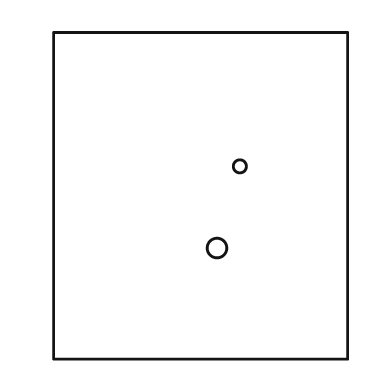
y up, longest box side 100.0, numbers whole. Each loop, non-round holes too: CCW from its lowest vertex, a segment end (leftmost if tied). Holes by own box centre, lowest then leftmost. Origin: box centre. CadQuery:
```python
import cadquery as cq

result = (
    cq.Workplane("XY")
    .moveTo(-45.0, -50.0)
    .lineTo(45.0, -50.0)
    .lineTo(45.0, 50.0)
    .lineTo(-45.0, 50.0)
    .close()
    .moveTo(5.0, -16.0)
    .circle(3.0)
    .moveTo(12.0, 9.0)
    .circle(2.0)
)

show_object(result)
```